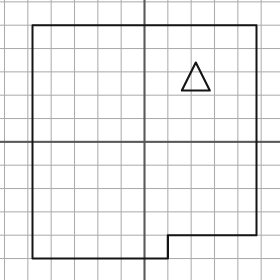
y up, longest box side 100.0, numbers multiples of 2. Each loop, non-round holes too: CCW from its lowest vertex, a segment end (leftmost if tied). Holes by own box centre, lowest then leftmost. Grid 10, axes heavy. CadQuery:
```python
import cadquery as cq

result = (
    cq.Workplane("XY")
    .moveTo(-48.0, -50.0)
    .lineTo(10.0, -50.0)
    .lineTo(10.0, -40.0)
    .lineTo(48.0, -40.0)
    .lineTo(48.0, 50.0)
    .lineTo(-48.0, 50.0)
    .close()
    .moveTo(16.0, 22.0)
    .lineTo(28.0, 22.0)
    .lineTo(22.0, 34.0)
    .close()
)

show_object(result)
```